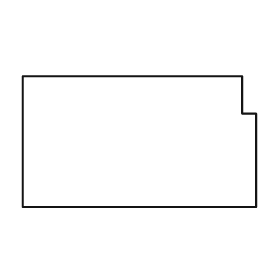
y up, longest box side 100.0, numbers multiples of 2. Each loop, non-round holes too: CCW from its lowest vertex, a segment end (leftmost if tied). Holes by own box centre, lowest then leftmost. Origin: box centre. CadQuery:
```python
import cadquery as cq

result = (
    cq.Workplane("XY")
    .moveTo(-50.0, -28.0)
    .lineTo(50.0, -28.0)
    .lineTo(50.0, 12.0)
    .lineTo(44.0, 12.0)
    .lineTo(44.0, 28.0)
    .lineTo(-50.0, 28.0)
    .close()
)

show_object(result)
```